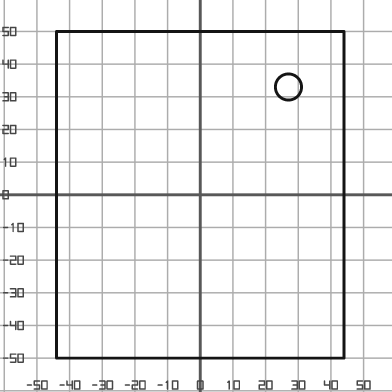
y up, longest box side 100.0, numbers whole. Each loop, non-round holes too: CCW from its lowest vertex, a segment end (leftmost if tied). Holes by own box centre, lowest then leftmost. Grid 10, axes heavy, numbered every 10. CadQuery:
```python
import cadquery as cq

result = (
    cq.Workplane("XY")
    .moveTo(-44.0, -50.0)
    .lineTo(44.0, -50.0)
    .lineTo(44.0, 50.0)
    .lineTo(-44.0, 50.0)
    .close()
    .moveTo(27.0, 33.0)
    .circle(4.0)
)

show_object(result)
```